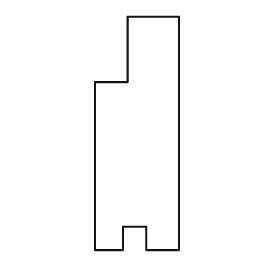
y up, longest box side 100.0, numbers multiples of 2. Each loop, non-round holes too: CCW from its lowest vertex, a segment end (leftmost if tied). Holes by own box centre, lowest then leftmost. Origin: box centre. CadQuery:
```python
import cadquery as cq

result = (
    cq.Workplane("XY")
    .moveTo(-18.0, -50.0)
    .lineTo(-6.0, -50.0)
    .lineTo(-6.0, -40.0)
    .lineTo(4.0, -40.0)
    .lineTo(4.0, -50.0)
    .lineTo(18.0, -50.0)
    .lineTo(18.0, 50.0)
    .lineTo(-4.0, 50.0)
    .lineTo(-4.0, 22.0)
    .lineTo(-18.0, 22.0)
    .close()
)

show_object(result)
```